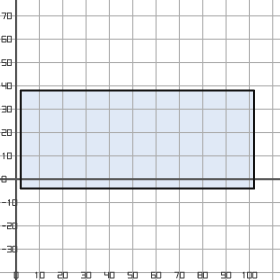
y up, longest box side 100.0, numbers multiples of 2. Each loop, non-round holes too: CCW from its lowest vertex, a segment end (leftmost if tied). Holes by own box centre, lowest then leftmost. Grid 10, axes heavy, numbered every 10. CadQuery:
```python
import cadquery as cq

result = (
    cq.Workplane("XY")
    .moveTo(2.0, -4.0)
    .lineTo(102.0, -4.0)
    .lineTo(102.0, 38.0)
    .lineTo(2.0, 38.0)
    .close()
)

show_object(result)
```